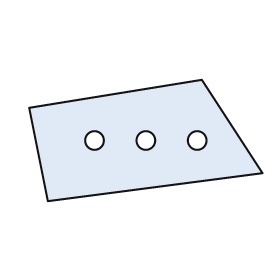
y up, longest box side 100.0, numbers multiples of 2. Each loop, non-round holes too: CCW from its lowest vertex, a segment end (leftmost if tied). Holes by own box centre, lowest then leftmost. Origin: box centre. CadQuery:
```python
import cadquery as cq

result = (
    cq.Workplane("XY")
    .moveTo(-42.0, -26.0)
    .lineTo(50.0, -14.0)
    .lineTo(24.0, 26.0)
    .lineTo(-50.0, 14.0)
    .close()
    .moveTo(-22.0, 0.0)
    .circle(4.0)
    .moveTo(0.0, 0.0)
    .circle(4.0)
    .moveTo(22.0, 0.0)
    .circle(4.0)
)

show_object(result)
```